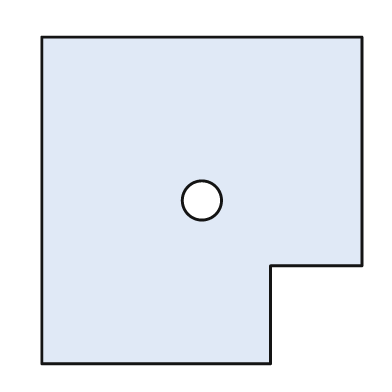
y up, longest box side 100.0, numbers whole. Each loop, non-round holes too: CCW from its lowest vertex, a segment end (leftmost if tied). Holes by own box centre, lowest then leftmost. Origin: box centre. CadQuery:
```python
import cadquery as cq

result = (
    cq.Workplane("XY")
    .moveTo(-49.0, -50.0)
    .lineTo(21.0, -50.0)
    .lineTo(21.0, -20.0)
    .lineTo(49.0, -20.0)
    .lineTo(49.0, 50.0)
    .lineTo(-49.0, 50.0)
    .close()
    .moveTo(0.0, 0.0)
    .circle(6.0)
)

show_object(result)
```